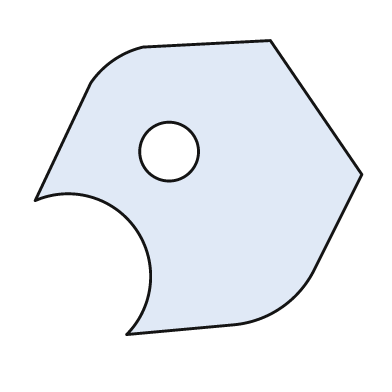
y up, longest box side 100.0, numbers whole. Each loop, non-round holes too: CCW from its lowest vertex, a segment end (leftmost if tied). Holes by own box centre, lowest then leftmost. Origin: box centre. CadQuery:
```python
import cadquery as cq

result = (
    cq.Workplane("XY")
    .moveTo(-22.0, -45.0)
    .lineTo(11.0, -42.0)
    .threePointArc((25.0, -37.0), (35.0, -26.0))
    .lineTo(50.0, 4.0)
    .lineTo(22.0, 45.0)
    .lineTo(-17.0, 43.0)
    .threePointArc((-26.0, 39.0), (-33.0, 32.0))
    .lineTo(-50.0, -4.0)
    .threePointArc((-19.0, -13.0), (-22.0, -45.0))
    .close()
    .moveTo(-9.0, 11.0)
    .circle(9.0)
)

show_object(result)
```